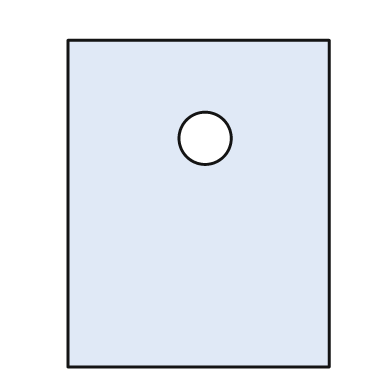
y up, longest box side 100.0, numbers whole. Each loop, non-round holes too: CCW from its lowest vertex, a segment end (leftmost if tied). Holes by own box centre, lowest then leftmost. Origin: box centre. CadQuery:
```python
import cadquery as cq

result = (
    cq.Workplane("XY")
    .moveTo(-40.0, -50.0)
    .lineTo(40.0, -50.0)
    .lineTo(40.0, 50.0)
    .lineTo(-40.0, 50.0)
    .close()
    .moveTo(2.0, 20.0)
    .circle(8.0)
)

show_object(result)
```